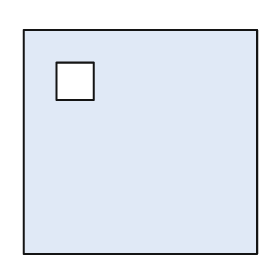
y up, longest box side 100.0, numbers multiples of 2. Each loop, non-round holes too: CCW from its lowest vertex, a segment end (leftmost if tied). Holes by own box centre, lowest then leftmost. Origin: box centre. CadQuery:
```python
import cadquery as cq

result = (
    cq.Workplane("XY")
    .moveTo(-50.0, -48.0)
    .lineTo(50.0, -48.0)
    .lineTo(50.0, 48.0)
    .lineTo(-50.0, 48.0)
    .close()
    .moveTo(-36.0, 18.0)
    .lineTo(-20.0, 18.0)
    .lineTo(-20.0, 34.0)
    .lineTo(-36.0, 34.0)
    .close()
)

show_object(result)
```